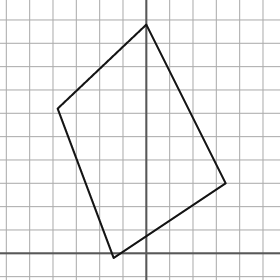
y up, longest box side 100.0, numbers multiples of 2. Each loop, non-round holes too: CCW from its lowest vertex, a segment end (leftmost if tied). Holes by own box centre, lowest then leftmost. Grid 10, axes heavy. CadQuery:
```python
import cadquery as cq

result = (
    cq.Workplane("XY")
    .moveTo(-14.0, -2.0)
    .lineTo(34.0, 30.0)
    .lineTo(0.0, 98.0)
    .lineTo(-38.0, 62.0)
    .close()
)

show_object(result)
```